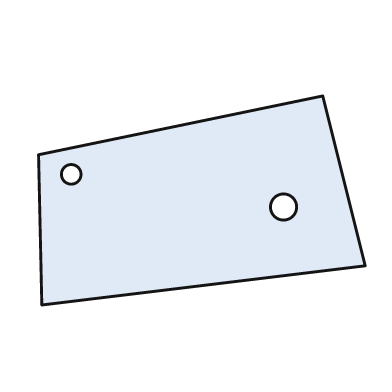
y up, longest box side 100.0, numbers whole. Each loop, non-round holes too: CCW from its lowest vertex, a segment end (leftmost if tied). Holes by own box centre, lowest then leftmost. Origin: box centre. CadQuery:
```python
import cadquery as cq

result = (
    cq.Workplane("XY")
    .moveTo(-49.0, -32.0)
    .lineTo(50.0, -20.0)
    .lineTo(37.0, 32.0)
    .lineTo(-50.0, 14.0)
    .close()
    .moveTo(25.0, -2.0)
    .circle(4.0)
    .moveTo(-40.0, 8.0)
    .circle(3.0)
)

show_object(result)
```